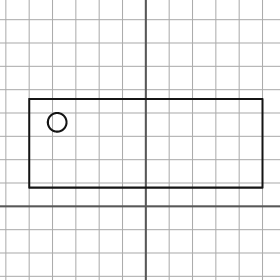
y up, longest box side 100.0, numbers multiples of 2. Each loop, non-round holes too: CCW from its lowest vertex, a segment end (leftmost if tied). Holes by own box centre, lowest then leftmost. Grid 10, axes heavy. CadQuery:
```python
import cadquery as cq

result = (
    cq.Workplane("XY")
    .moveTo(-50.0, 8.0)
    .lineTo(50.0, 8.0)
    .lineTo(50.0, 46.0)
    .lineTo(-50.0, 46.0)
    .close()
    .moveTo(-38.0, 36.0)
    .circle(4.0)
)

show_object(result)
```